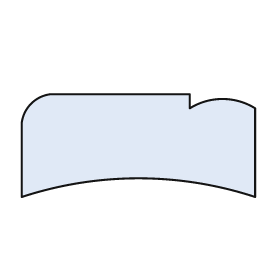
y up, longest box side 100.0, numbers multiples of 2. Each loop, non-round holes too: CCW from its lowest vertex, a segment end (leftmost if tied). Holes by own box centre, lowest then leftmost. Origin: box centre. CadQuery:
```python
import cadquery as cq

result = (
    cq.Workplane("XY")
    .moveTo(-50.0, -22.0)
    .threePointArc((0.0, -14.0), (50.0, -22.0))
    .lineTo(50.0, 16.0)
    .threePointArc((36.0, 20.0), (22.0, 16.0))
    .lineTo(22.0, 22.0)
    .lineTo(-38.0, 22.0)
    .threePointArc((-46.0, 18.0), (-50.0, 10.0))
    .close()
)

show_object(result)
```